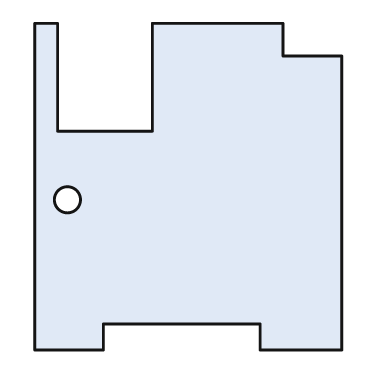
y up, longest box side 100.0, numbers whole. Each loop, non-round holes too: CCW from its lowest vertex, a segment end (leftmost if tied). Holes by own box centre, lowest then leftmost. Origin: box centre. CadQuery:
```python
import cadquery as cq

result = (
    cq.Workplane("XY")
    .moveTo(-47.0, -50.0)
    .lineTo(-26.0, -50.0)
    .lineTo(-26.0, -42.0)
    .lineTo(22.0, -42.0)
    .lineTo(22.0, -50.0)
    .lineTo(47.0, -50.0)
    .lineTo(47.0, 40.0)
    .lineTo(29.0, 40.0)
    .lineTo(29.0, 50.0)
    .lineTo(-11.0, 50.0)
    .lineTo(-11.0, 17.0)
    .lineTo(-40.0, 17.0)
    .lineTo(-40.0, 50.0)
    .lineTo(-47.0, 50.0)
    .close()
    .moveTo(-37.0, -4.0)
    .circle(4.0)
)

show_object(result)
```